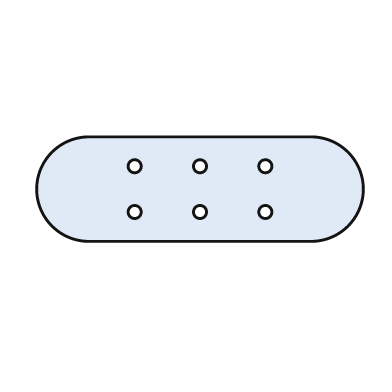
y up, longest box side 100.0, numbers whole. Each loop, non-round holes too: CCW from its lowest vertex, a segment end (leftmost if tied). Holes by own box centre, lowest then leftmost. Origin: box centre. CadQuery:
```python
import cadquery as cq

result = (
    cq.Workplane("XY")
    .moveTo(-34.0, -16.0)
    .lineTo(34.0, -16.0)
    .threePointArc((50.0, 0.0), (34.0, 16.0))
    .lineTo(-34.0, 16.0)
    .threePointArc((-50.0, 0.0), (-34.0, -16.0))
    .close()
    .moveTo(-20.0, -7.0)
    .circle(2.0)
    .moveTo(0.0, -7.0)
    .circle(2.0)
    .moveTo(20.0, -7.0)
    .circle(2.0)
    .moveTo(-20.0, 7.0)
    .circle(2.0)
    .moveTo(0.0, 7.0)
    .circle(2.0)
    .moveTo(20.0, 7.0)
    .circle(2.0)
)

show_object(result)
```